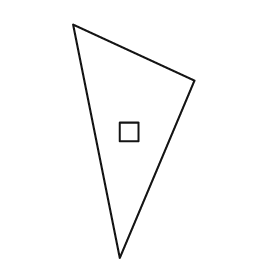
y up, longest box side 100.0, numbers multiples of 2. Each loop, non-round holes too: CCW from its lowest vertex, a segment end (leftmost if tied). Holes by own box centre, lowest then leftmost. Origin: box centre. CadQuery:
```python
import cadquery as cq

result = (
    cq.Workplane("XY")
    .moveTo(-6.0, -50.0)
    .lineTo(26.0, 26.0)
    .lineTo(-26.0, 50.0)
    .close()
    .moveTo(-6.0, 0.0)
    .lineTo(2.0, 0.0)
    .lineTo(2.0, 8.0)
    .lineTo(-6.0, 8.0)
    .close()
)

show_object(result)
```